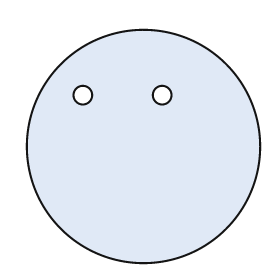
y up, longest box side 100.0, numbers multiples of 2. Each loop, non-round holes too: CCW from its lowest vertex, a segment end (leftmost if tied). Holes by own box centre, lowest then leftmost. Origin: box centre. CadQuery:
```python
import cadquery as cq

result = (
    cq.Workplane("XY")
    .moveTo(0.0, 0.0)
    .circle(50.0)
    .moveTo(-26.0, 22.0)
    .circle(4.0)
    .moveTo(8.0, 22.0)
    .circle(4.0)
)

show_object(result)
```